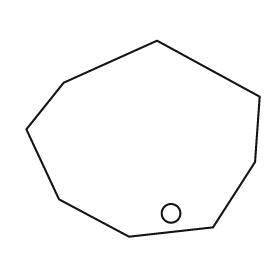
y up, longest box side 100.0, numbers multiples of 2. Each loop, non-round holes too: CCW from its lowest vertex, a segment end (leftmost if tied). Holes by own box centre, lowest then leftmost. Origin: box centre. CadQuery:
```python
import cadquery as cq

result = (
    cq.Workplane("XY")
    .moveTo(-6.0, -42.0)
    .lineTo(30.0, -38.0)
    .lineTo(48.0, -10.0)
    .lineTo(50.0, 18.0)
    .lineTo(6.0, 42.0)
    .lineTo(-34.0, 24.0)
    .lineTo(-50.0, 4.0)
    .lineTo(-36.0, -26.0)
    .close()
    .moveTo(12.0, -32.0)
    .circle(4.0)
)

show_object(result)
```